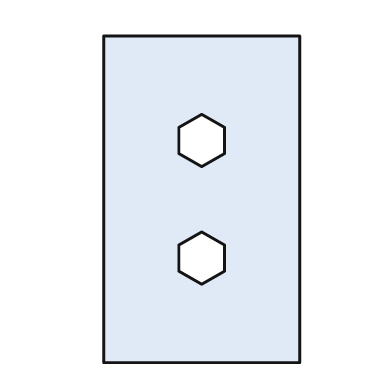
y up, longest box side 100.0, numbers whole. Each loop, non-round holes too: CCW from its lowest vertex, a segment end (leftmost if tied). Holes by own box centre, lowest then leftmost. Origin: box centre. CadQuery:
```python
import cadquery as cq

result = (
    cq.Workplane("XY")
    .moveTo(-30.0, -50.0)
    .lineTo(30.0, -50.0)
    .lineTo(30.0, 50.0)
    .lineTo(-30.0, 50.0)
    .close()
    .moveTo(0.0, -26.0)
    .lineTo(7.0, -22.0)
    .lineTo(7.0, -14.0)
    .lineTo(0.0, -10.0)
    .lineTo(-7.0, -14.0)
    .lineTo(-7.0, -22.0)
    .close()
    .moveTo(0.0, 10.0)
    .lineTo(7.0, 14.0)
    .lineTo(7.0, 22.0)
    .lineTo(0.0, 26.0)
    .lineTo(-7.0, 22.0)
    .lineTo(-7.0, 14.0)
    .close()
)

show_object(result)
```